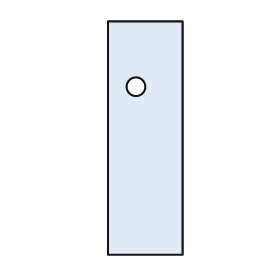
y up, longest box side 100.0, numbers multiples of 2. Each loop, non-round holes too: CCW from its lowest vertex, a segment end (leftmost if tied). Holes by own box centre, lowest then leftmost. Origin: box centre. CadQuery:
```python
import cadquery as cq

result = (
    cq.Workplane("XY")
    .moveTo(-16.0, -50.0)
    .lineTo(16.0, -50.0)
    .lineTo(16.0, 50.0)
    .lineTo(-16.0, 50.0)
    .close()
    .moveTo(-4.0, 22.0)
    .circle(4.0)
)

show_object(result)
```